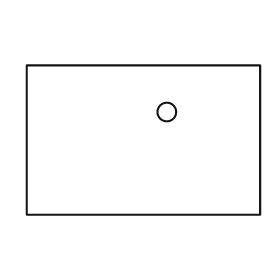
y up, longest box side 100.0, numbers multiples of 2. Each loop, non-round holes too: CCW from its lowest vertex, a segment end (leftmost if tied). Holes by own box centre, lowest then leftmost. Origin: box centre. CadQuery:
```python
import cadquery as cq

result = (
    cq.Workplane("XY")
    .moveTo(-50.0, -32.0)
    .lineTo(50.0, -32.0)
    .lineTo(50.0, 32.0)
    .lineTo(-50.0, 32.0)
    .close()
    .moveTo(10.0, 12.0)
    .circle(4.0)
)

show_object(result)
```